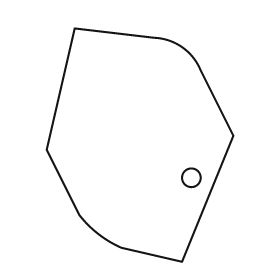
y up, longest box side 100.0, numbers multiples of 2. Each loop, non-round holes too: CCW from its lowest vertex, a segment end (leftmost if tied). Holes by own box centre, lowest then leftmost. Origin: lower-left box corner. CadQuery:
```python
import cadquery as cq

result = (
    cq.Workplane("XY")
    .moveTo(58.0, 0.0)
    .lineTo(80.0, 54.0)
    .lineTo(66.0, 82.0)
    .threePointArc((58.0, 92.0), (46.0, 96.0))
    .lineTo(12.0, 100.0)
    .lineTo(0.0, 48.0)
    .lineTo(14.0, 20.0)
    .threePointArc((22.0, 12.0), (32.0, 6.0))
    .close()
    .moveTo(62.0, 36.0)
    .circle(4.0)
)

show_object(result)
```